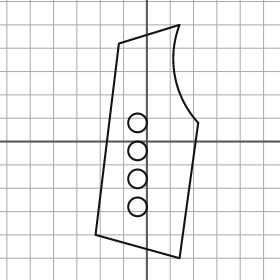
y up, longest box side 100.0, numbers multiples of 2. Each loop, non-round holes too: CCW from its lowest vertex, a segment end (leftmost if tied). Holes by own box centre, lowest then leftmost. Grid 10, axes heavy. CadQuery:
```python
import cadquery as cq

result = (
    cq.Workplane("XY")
    .moveTo(14.0, -50.0)
    .lineTo(22.0, 8.0)
    .threePointArc((12.0, 28.0), (14.0, 50.0))
    .lineTo(-12.0, 42.0)
    .lineTo(-22.0, -40.0)
    .close()
    .moveTo(-4.0, -28.0)
    .circle(4.0)
    .moveTo(-4.0, -16.0)
    .circle(4.0)
    .moveTo(-4.0, -4.0)
    .circle(4.0)
    .moveTo(-4.0, 8.0)
    .circle(4.0)
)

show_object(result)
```